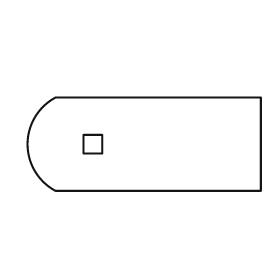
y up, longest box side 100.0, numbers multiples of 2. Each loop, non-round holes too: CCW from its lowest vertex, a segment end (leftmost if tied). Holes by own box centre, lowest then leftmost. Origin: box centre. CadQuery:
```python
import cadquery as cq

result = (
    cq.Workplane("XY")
    .moveTo(-38.0, -20.0)
    .lineTo(50.0, -20.0)
    .lineTo(50.0, 20.0)
    .lineTo(-38.0, 20.0)
    .threePointArc((-50.0, 0.0), (-38.0, -20.0))
    .close()
    .moveTo(-26.0, -4.0)
    .lineTo(-18.0, -4.0)
    .lineTo(-18.0, 4.0)
    .lineTo(-26.0, 4.0)
    .close()
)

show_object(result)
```